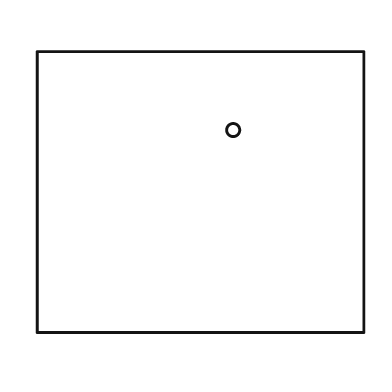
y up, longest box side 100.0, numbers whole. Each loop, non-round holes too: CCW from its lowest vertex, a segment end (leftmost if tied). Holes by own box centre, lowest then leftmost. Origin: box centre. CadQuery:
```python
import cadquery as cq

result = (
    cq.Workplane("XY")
    .moveTo(-50.0, -43.0)
    .lineTo(50.0, -43.0)
    .lineTo(50.0, 43.0)
    .lineTo(-50.0, 43.0)
    .close()
    .moveTo(10.0, 19.0)
    .circle(2.0)
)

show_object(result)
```